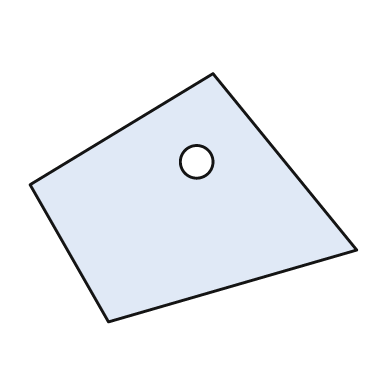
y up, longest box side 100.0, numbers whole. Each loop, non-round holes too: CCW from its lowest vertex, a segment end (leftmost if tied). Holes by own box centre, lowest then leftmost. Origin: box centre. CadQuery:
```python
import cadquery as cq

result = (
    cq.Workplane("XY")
    .moveTo(-26.0, -38.0)
    .lineTo(50.0, -16.0)
    .lineTo(6.0, 38.0)
    .lineTo(-50.0, 4.0)
    .close()
    .moveTo(1.0, 11.0)
    .circle(5.0)
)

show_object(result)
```